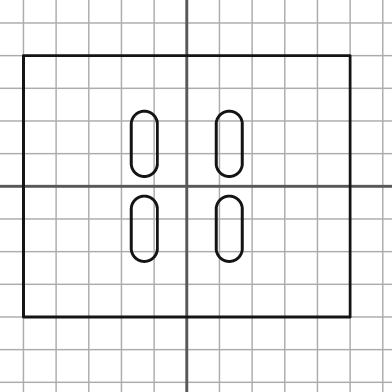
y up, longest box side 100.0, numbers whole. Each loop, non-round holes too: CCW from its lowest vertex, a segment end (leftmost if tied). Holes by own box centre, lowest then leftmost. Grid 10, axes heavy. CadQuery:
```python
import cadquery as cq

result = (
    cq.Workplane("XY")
    .moveTo(-50.0, -40.0)
    .lineTo(50.0, -40.0)
    .lineTo(50.0, 40.0)
    .lineTo(-50.0, 40.0)
    .close()
    .moveTo(-17.0, -19.0)
    .threePointArc((-13.0, -23.0), (-9.0, -19.0))
    .lineTo(-9.0, -7.0)
    .threePointArc((-13.0, -3.0), (-17.0, -7.0))
    .close()
    .moveTo(9.0, -19.0)
    .threePointArc((13.0, -23.0), (17.0, -19.0))
    .lineTo(17.0, -7.0)
    .threePointArc((13.0, -3.0), (9.0, -7.0))
    .close()
    .moveTo(-17.0, 7.0)
    .threePointArc((-13.0, 3.0), (-9.0, 7.0))
    .lineTo(-9.0, 19.0)
    .threePointArc((-13.0, 23.0), (-17.0, 19.0))
    .close()
    .moveTo(9.0, 7.0)
    .threePointArc((13.0, 3.0), (17.0, 7.0))
    .lineTo(17.0, 19.0)
    .threePointArc((13.0, 23.0), (9.0, 19.0))
    .close()
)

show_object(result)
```